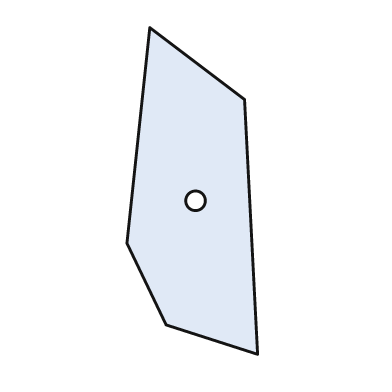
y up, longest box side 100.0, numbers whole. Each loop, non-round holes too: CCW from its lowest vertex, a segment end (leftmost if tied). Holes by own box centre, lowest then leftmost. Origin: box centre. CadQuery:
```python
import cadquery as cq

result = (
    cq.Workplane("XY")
    .moveTo(20.0, -50.0)
    .lineTo(16.0, 28.0)
    .lineTo(-13.0, 50.0)
    .lineTo(-20.0, -16.0)
    .lineTo(-8.0, -41.0)
    .close()
    .moveTo(1.0, -3.0)
    .circle(3.0)
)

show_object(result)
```